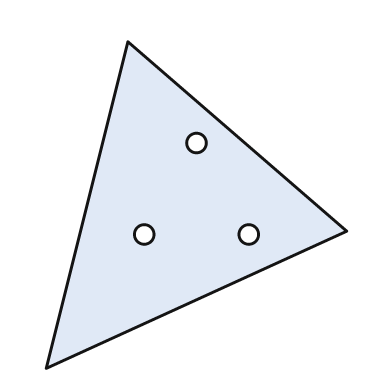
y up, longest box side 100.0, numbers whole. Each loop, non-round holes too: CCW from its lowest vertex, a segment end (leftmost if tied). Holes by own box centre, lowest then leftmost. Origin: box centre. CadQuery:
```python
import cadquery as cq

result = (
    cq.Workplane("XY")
    .moveTo(-46.0, -50.0)
    .lineTo(46.0, -8.0)
    .lineTo(-21.0, 50.0)
    .close()
    .moveTo(-16.0, -9.0)
    .circle(3.0)
    .moveTo(16.0, -9.0)
    .circle(3.0)
    .moveTo(0.0, 19.0)
    .circle(3.0)
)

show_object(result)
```